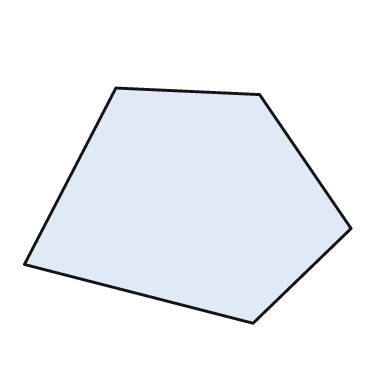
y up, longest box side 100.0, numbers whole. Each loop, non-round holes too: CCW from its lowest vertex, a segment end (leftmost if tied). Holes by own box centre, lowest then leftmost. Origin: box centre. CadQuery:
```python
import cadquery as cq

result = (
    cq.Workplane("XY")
    .moveTo(20.0, -36.0)
    .lineTo(50.0, -7.0)
    .lineTo(22.0, 34.0)
    .lineTo(-22.0, 36.0)
    .lineTo(-50.0, -18.0)
    .close()
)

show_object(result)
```